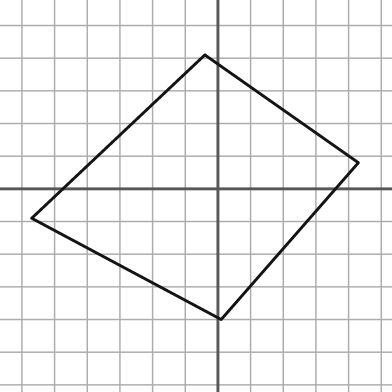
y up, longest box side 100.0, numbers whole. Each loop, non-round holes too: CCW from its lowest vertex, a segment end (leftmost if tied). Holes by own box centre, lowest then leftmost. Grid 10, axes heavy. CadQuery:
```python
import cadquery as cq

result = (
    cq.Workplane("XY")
    .moveTo(1.0, -40.0)
    .lineTo(43.0, 8.0)
    .lineTo(-4.0, 41.0)
    .lineTo(-57.0, -9.0)
    .close()
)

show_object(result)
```